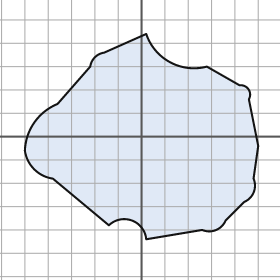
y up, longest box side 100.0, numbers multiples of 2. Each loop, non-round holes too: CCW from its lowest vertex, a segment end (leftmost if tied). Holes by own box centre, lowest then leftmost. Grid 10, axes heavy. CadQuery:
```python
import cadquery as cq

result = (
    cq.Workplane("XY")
    .moveTo(2.0, -44.0)
    .lineTo(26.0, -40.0)
    .threePointArc((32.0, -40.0), (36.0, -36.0))
    .lineTo(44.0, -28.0)
    .threePointArc((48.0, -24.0), (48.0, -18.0))
    .lineTo(50.0, -4.0)
    .lineTo(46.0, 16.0)
    .threePointArc((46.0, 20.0), (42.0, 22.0))
    .lineTo(28.0, 30.0)
    .threePointArc((12.0, 32.0), (2.0, 44.0))
    .lineTo(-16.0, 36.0)
    .threePointArc((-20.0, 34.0), (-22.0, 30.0))
    .lineTo(-36.0, 14.0)
    .threePointArc((-46.0, 6.0), (-50.0, -6.0))
    .threePointArc((-46.0, -14.0), (-38.0, -18.0))
    .lineTo(-14.0, -38.0)
    .threePointArc((-4.0, -36.0), (2.0, -44.0))
    .close()
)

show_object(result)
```